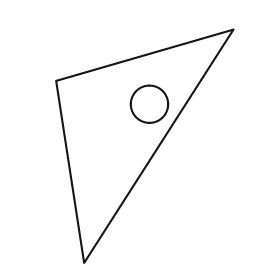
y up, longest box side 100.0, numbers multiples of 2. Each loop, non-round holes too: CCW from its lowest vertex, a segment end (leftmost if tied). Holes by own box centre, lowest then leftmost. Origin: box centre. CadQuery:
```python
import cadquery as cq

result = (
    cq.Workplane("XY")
    .moveTo(-26.0, -50.0)
    .lineTo(38.0, 50.0)
    .lineTo(-38.0, 28.0)
    .close()
    .moveTo(2.0, 18.0)
    .circle(8.0)
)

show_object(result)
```